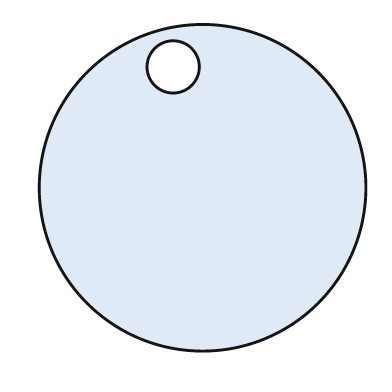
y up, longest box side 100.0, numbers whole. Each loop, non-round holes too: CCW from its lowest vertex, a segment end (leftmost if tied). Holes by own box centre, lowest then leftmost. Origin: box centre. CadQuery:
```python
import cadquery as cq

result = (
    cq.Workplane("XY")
    .moveTo(0.0, 0.0)
    .circle(50.0)
    .moveTo(-9.0, 37.0)
    .circle(8.0)
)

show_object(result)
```